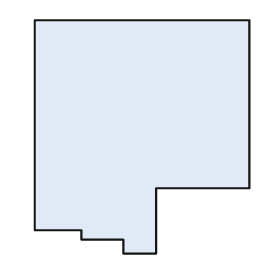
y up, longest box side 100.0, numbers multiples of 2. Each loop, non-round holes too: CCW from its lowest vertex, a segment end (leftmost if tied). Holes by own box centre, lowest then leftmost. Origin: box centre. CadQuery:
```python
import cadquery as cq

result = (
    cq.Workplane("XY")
    .moveTo(-8.0, -50.0)
    .lineTo(6.0, -50.0)
    .lineTo(6.0, -22.0)
    .lineTo(46.0, -22.0)
    .lineTo(46.0, 50.0)
    .lineTo(-46.0, 50.0)
    .lineTo(-46.0, -40.0)
    .lineTo(-26.0, -40.0)
    .lineTo(-26.0, -44.0)
    .lineTo(-8.0, -44.0)
    .close()
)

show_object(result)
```